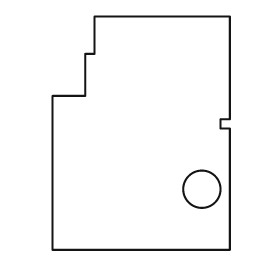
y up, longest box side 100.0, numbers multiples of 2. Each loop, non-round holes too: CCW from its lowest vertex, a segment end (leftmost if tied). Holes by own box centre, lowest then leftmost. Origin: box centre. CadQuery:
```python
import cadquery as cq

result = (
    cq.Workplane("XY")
    .moveTo(-38.0, -50.0)
    .lineTo(38.0, -50.0)
    .lineTo(38.0, 2.0)
    .lineTo(34.0, 2.0)
    .lineTo(34.0, 6.0)
    .lineTo(38.0, 6.0)
    .lineTo(38.0, 50.0)
    .lineTo(-20.0, 50.0)
    .lineTo(-20.0, 34.0)
    .lineTo(-24.0, 34.0)
    .lineTo(-24.0, 16.0)
    .lineTo(-38.0, 16.0)
    .close()
    .moveTo(26.0, -24.0)
    .circle(8.0)
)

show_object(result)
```